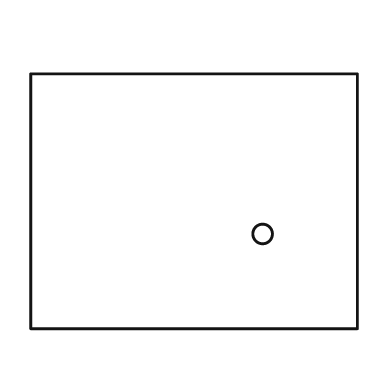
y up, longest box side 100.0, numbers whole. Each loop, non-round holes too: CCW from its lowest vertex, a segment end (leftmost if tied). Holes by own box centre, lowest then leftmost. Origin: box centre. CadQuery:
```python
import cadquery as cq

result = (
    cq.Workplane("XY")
    .moveTo(-50.0, -39.0)
    .lineTo(50.0, -39.0)
    .lineTo(50.0, 39.0)
    .lineTo(-50.0, 39.0)
    .close()
    .moveTo(21.0, -10.0)
    .circle(3.0)
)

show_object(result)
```